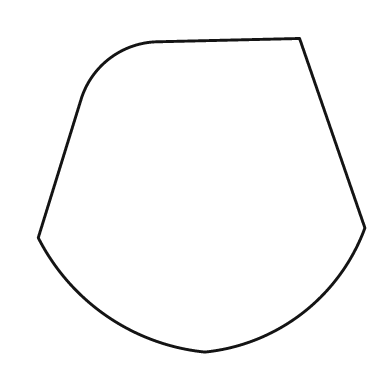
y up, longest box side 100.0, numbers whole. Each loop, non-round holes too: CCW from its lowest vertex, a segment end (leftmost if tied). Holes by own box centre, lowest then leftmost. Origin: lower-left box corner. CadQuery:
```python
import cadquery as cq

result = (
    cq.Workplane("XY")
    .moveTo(51.0, 0.0)
    .threePointArc((81.0, 12.0), (100.0, 38.0))
    .lineTo(80.0, 96.0)
    .lineTo(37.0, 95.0)
    .threePointArc((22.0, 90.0), (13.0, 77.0))
    .lineTo(0.0, 35.0)
    .threePointArc((21.0, 11.0), (51.0, 0.0))
    .close()
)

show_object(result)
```